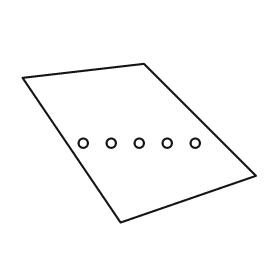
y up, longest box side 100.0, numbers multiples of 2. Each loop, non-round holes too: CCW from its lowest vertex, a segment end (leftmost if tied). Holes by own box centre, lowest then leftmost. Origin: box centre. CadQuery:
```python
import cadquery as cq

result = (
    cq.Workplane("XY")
    .moveTo(-8.0, -34.0)
    .lineTo(50.0, -14.0)
    .lineTo(2.0, 34.0)
    .lineTo(-50.0, 28.0)
    .close()
    .moveTo(-24.0, 0.0)
    .circle(2.0)
    .moveTo(-12.0, 0.0)
    .circle(2.0)
    .moveTo(0.0, 0.0)
    .circle(2.0)
    .moveTo(12.0, 0.0)
    .circle(2.0)
    .moveTo(24.0, 0.0)
    .circle(2.0)
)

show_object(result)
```